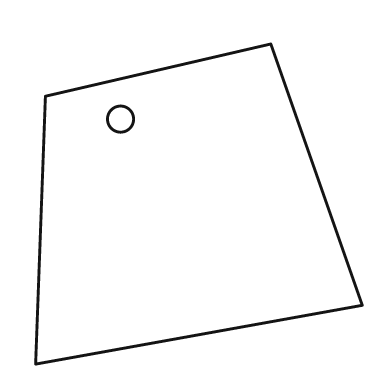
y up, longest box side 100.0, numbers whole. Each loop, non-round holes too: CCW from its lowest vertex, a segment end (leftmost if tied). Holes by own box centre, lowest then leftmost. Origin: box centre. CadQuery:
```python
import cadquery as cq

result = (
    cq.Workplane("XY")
    .moveTo(-50.0, -49.0)
    .lineTo(50.0, -31.0)
    .lineTo(22.0, 49.0)
    .lineTo(-47.0, 33.0)
    .close()
    .moveTo(-24.0, 26.0)
    .circle(4.0)
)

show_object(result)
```